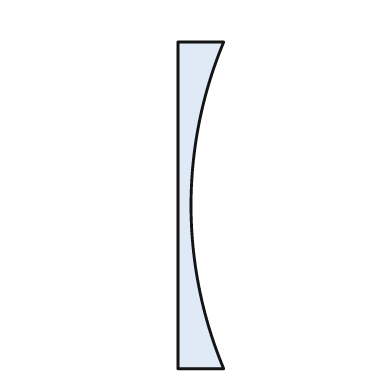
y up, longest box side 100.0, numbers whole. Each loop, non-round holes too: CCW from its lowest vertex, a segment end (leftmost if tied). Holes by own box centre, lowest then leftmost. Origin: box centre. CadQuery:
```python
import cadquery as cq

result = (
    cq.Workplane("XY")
    .moveTo(-7.0, -50.0)
    .lineTo(7.0, -50.0)
    .threePointArc((-3.0, 0.0), (7.0, 50.0))
    .lineTo(-7.0, 50.0)
    .close()
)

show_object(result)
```